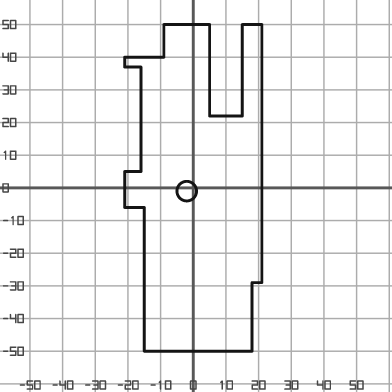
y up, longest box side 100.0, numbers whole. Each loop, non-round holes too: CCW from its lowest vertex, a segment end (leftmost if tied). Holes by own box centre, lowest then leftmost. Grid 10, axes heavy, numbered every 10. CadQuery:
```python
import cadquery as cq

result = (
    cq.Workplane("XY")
    .moveTo(-15.0, -50.0)
    .lineTo(18.0, -50.0)
    .lineTo(18.0, -29.0)
    .lineTo(21.0, -29.0)
    .lineTo(21.0, 50.0)
    .lineTo(15.0, 50.0)
    .lineTo(15.0, 22.0)
    .lineTo(5.0, 22.0)
    .lineTo(5.0, 50.0)
    .lineTo(-9.0, 50.0)
    .lineTo(-9.0, 40.0)
    .lineTo(-21.0, 40.0)
    .lineTo(-21.0, 37.0)
    .lineTo(-16.0, 37.0)
    .lineTo(-16.0, 5.0)
    .lineTo(-21.0, 5.0)
    .lineTo(-21.0, -6.0)
    .lineTo(-15.0, -6.0)
    .close()
    .moveTo(-2.0, -1.0)
    .circle(3.0)
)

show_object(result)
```